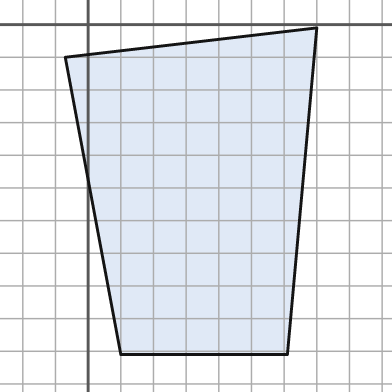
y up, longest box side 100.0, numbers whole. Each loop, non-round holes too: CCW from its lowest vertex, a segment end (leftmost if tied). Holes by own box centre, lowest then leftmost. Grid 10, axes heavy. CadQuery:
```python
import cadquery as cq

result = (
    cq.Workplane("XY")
    .moveTo(10.0, -101.0)
    .lineTo(61.0, -101.0)
    .lineTo(70.0, -1.0)
    .lineTo(-7.0, -10.0)
    .close()
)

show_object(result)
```